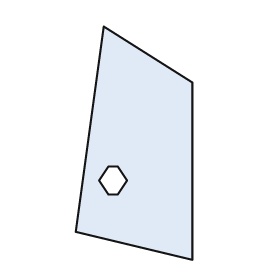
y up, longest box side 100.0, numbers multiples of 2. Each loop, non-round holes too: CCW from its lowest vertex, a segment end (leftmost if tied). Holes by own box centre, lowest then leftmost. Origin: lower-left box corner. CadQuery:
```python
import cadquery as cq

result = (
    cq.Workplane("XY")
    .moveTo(50.0, 0.0)
    .lineTo(50.0, 76.0)
    .lineTo(12.0, 100.0)
    .lineTo(0.0, 12.0)
    .close()
    .moveTo(14.0, 28.0)
    .lineTo(18.0, 28.0)
    .lineTo(22.0, 34.0)
    .lineTo(18.0, 40.0)
    .lineTo(14.0, 40.0)
    .lineTo(10.0, 34.0)
    .close()
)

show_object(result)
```